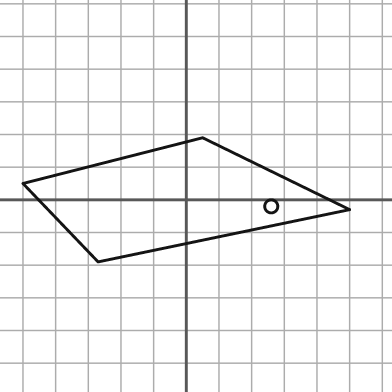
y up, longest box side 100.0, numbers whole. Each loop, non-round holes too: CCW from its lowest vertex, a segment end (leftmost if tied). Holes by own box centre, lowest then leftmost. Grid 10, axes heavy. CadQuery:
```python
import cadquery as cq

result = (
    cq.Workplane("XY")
    .moveTo(-27.0, -19.0)
    .lineTo(50.0, -3.0)
    .lineTo(5.0, 19.0)
    .lineTo(-50.0, 5.0)
    .close()
    .moveTo(26.0, -2.0)
    .circle(2.0)
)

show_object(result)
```